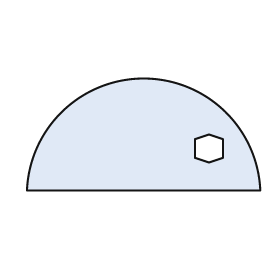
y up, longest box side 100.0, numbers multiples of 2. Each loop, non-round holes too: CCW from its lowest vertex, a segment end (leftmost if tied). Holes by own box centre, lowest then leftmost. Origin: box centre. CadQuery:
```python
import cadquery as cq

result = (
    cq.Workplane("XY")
    .moveTo(-50.0, -24.0)
    .lineTo(50.0, -24.0)
    .threePointArc((0.0, 24.0), (-50.0, -24.0))
    .close()
    .moveTo(28.0, -12.0)
    .lineTo(34.0, -10.0)
    .lineTo(34.0, -2.0)
    .lineTo(28.0, 0.0)
    .lineTo(22.0, -2.0)
    .lineTo(22.0, -10.0)
    .close()
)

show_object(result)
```